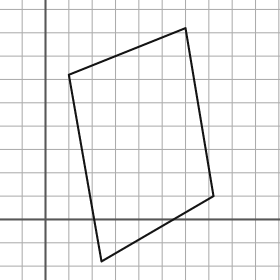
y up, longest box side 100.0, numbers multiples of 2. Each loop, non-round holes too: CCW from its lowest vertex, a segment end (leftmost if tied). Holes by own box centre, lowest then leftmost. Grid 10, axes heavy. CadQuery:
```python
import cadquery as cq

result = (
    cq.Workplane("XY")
    .moveTo(24.0, -18.0)
    .lineTo(72.0, 10.0)
    .lineTo(60.0, 82.0)
    .lineTo(10.0, 62.0)
    .close()
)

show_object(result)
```